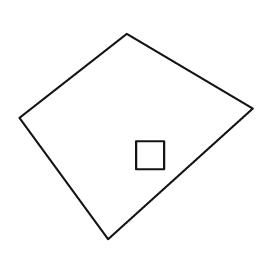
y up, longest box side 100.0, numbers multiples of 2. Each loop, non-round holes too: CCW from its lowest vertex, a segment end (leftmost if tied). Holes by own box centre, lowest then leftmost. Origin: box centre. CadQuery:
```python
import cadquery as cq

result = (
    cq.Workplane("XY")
    .moveTo(-12.0, -44.0)
    .lineTo(50.0, 12.0)
    .lineTo(-4.0, 44.0)
    .lineTo(-50.0, 8.0)
    .close()
    .moveTo(0.0, -14.0)
    .lineTo(12.0, -14.0)
    .lineTo(12.0, -2.0)
    .lineTo(0.0, -2.0)
    .close()
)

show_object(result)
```